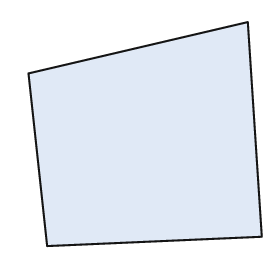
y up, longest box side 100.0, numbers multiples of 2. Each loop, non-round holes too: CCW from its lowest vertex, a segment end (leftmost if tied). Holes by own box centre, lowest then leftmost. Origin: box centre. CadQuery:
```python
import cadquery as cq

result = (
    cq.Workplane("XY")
    .moveTo(-42.0, -48.0)
    .lineTo(50.0, -44.0)
    .lineTo(44.0, 48.0)
    .lineTo(-50.0, 26.0)
    .close()
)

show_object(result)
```